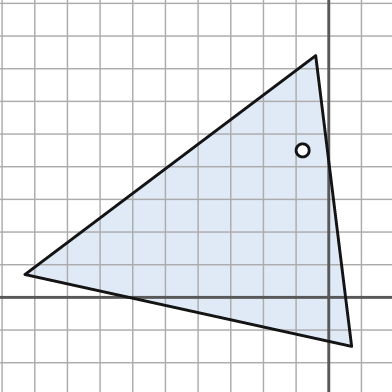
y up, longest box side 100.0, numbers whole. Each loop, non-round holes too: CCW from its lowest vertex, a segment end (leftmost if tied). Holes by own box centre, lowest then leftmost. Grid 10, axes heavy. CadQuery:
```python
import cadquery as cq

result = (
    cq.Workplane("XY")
    .moveTo(7.0, -15.0)
    .lineTo(-4.0, 74.0)
    .lineTo(-93.0, 7.0)
    .close()
    .moveTo(-8.0, 45.0)
    .circle(2.0)
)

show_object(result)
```